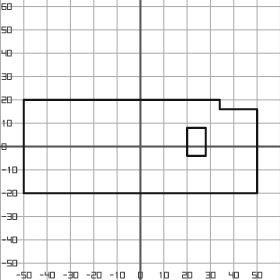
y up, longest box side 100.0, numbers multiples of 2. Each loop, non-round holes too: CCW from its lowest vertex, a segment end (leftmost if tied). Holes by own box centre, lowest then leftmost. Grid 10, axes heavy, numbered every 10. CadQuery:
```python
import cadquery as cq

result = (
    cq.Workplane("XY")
    .moveTo(-50.0, -20.0)
    .lineTo(50.0, -20.0)
    .lineTo(50.0, 16.0)
    .lineTo(34.0, 16.0)
    .lineTo(34.0, 20.0)
    .lineTo(-50.0, 20.0)
    .close()
    .moveTo(20.0, -4.0)
    .lineTo(28.0, -4.0)
    .lineTo(28.0, 8.0)
    .lineTo(20.0, 8.0)
    .close()
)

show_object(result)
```